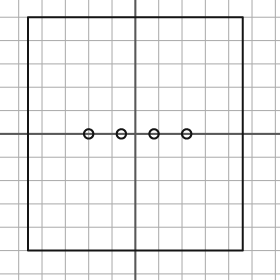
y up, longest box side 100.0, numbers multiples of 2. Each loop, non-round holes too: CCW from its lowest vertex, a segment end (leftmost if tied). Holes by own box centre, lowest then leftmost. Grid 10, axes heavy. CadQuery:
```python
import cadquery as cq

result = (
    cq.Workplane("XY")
    .moveTo(-46.0, -50.0)
    .lineTo(46.0, -50.0)
    .lineTo(46.0, 50.0)
    .lineTo(-46.0, 50.0)
    .close()
    .moveTo(-20.0, 0.0)
    .circle(2.0)
    .moveTo(-6.0, 0.0)
    .circle(2.0)
    .moveTo(8.0, 0.0)
    .circle(2.0)
    .moveTo(22.0, 0.0)
    .circle(2.0)
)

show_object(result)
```